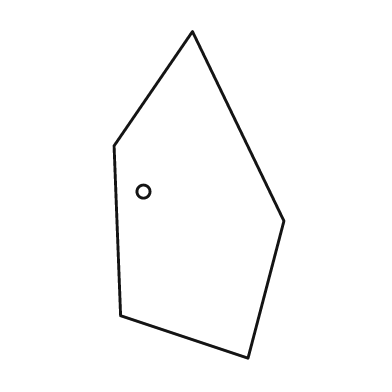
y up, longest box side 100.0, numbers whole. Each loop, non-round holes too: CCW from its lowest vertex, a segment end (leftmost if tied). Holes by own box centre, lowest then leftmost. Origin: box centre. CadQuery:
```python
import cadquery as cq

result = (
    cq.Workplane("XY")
    .moveTo(15.0, -50.0)
    .lineTo(26.0, -8.0)
    .lineTo(-2.0, 50.0)
    .lineTo(-26.0, 15.0)
    .lineTo(-24.0, -37.0)
    .close()
    .moveTo(-17.0, 1.0)
    .circle(2.0)
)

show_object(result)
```